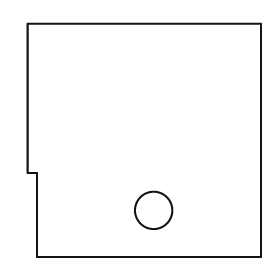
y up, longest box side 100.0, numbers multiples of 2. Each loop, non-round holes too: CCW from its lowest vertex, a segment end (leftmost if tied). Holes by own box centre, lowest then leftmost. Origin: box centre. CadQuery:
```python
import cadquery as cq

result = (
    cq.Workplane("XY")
    .moveTo(-46.0, -50.0)
    .lineTo(50.0, -50.0)
    .lineTo(50.0, 50.0)
    .lineTo(-50.0, 50.0)
    .lineTo(-50.0, -14.0)
    .lineTo(-46.0, -14.0)
    .close()
    .moveTo(4.0, -30.0)
    .circle(8.0)
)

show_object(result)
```